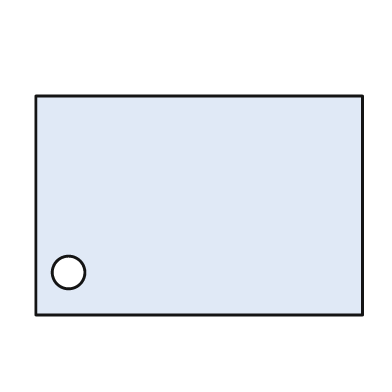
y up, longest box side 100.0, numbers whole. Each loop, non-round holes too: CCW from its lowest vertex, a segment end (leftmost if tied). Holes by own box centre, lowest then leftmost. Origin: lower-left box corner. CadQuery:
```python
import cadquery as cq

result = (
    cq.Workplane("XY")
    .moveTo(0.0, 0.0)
    .lineTo(100.0, 0.0)
    .lineTo(100.0, 67.0)
    .lineTo(0.0, 67.0)
    .close()
    .moveTo(10.0, 13.0)
    .circle(5.0)
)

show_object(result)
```